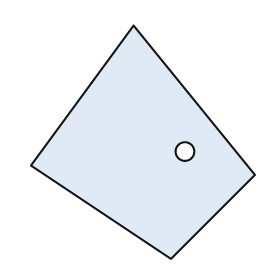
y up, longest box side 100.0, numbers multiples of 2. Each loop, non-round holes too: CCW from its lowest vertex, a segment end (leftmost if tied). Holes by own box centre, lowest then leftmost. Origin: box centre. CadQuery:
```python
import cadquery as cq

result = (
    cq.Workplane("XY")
    .moveTo(12.0, -50.0)
    .lineTo(48.0, -14.0)
    .lineTo(-4.0, 50.0)
    .lineTo(-48.0, -10.0)
    .close()
    .moveTo(18.0, -4.0)
    .circle(4.0)
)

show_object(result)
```